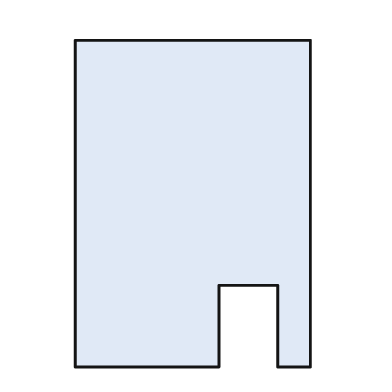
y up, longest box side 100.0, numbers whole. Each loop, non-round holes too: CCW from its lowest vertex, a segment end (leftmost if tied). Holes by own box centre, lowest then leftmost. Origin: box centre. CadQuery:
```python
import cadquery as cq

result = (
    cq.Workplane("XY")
    .moveTo(-36.0, -50.0)
    .lineTo(8.0, -50.0)
    .lineTo(8.0, -25.0)
    .lineTo(26.0, -25.0)
    .lineTo(26.0, -50.0)
    .lineTo(36.0, -50.0)
    .lineTo(36.0, 50.0)
    .lineTo(-36.0, 50.0)
    .close()
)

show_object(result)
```